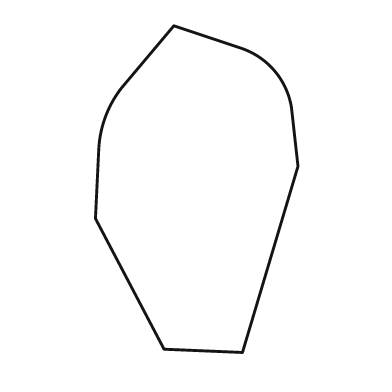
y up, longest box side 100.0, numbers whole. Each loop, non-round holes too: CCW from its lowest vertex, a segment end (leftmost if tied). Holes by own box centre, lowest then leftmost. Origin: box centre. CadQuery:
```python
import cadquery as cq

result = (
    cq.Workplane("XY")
    .moveTo(14.0, -50.0)
    .lineTo(31.0, 7.0)
    .lineTo(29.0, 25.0)
    .threePointArc((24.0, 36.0), (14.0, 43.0))
    .lineTo(-7.0, 50.0)
    .lineTo(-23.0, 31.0)
    .threePointArc((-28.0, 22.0), (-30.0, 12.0))
    .lineTo(-31.0, -9.0)
    .lineTo(-10.0, -49.0)
    .close()
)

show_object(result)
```